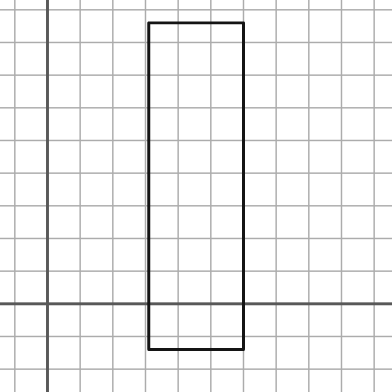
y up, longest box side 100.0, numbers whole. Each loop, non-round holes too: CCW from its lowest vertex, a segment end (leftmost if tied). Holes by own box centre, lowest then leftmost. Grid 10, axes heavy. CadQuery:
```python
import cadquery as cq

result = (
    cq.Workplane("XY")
    .moveTo(31.0, -14.0)
    .lineTo(60.0, -14.0)
    .lineTo(60.0, 86.0)
    .lineTo(31.0, 86.0)
    .close()
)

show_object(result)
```